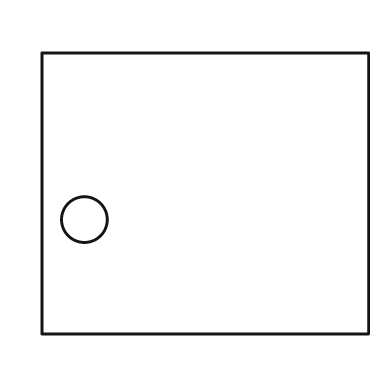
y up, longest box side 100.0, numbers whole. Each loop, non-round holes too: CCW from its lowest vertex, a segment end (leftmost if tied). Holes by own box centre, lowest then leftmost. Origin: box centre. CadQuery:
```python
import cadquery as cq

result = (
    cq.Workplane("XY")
    .moveTo(-50.0, -43.0)
    .lineTo(50.0, -43.0)
    .lineTo(50.0, 43.0)
    .lineTo(-50.0, 43.0)
    .close()
    .moveTo(-37.0, -8.0)
    .circle(7.0)
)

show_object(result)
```